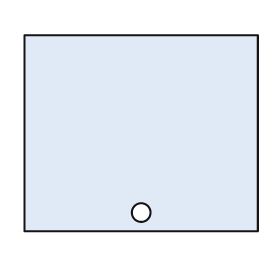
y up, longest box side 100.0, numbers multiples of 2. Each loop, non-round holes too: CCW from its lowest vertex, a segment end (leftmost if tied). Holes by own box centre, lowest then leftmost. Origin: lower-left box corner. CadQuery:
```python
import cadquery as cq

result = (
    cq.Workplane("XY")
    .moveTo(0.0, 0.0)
    .lineTo(100.0, 0.0)
    .lineTo(100.0, 84.0)
    .lineTo(0.0, 84.0)
    .close()
    .moveTo(50.0, 8.0)
    .circle(4.0)
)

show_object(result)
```